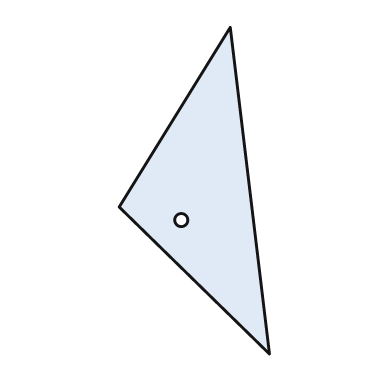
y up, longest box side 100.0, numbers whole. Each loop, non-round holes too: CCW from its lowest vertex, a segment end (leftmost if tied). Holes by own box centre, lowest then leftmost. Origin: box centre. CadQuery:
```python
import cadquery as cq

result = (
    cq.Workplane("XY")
    .moveTo(23.0, -50.0)
    .lineTo(11.0, 50.0)
    .lineTo(-23.0, -5.0)
    .close()
    .moveTo(-4.0, -9.0)
    .circle(2.0)
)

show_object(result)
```